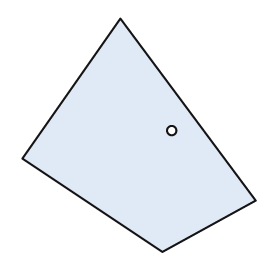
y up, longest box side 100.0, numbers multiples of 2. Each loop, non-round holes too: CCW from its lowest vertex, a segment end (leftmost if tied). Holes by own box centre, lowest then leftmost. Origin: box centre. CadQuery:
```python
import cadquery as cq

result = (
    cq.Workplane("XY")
    .moveTo(10.0, -50.0)
    .lineTo(50.0, -28.0)
    .lineTo(-8.0, 50.0)
    .lineTo(-50.0, -10.0)
    .close()
    .moveTo(14.0, 2.0)
    .circle(2.0)
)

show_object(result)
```